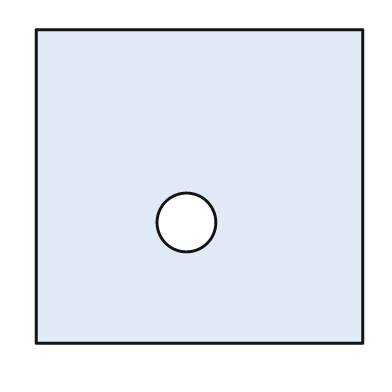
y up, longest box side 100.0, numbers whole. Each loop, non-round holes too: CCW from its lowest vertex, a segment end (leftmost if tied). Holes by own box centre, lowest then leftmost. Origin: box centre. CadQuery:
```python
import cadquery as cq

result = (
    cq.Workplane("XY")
    .moveTo(-50.0, -48.0)
    .lineTo(50.0, -48.0)
    .lineTo(50.0, 48.0)
    .lineTo(-50.0, 48.0)
    .close()
    .moveTo(-4.0, -11.0)
    .circle(9.0)
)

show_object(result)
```